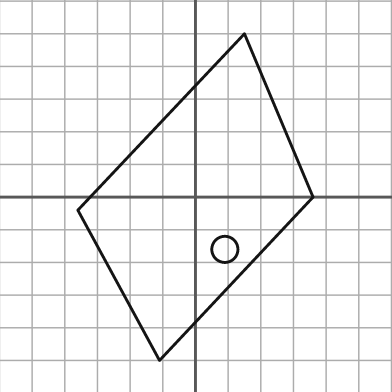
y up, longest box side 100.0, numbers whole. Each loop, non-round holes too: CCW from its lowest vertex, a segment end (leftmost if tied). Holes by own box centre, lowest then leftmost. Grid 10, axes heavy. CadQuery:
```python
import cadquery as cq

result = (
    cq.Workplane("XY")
    .moveTo(-11.0, -50.0)
    .lineTo(36.0, 0.0)
    .lineTo(15.0, 50.0)
    .lineTo(-36.0, -4.0)
    .close()
    .moveTo(9.0, -16.0)
    .circle(4.0)
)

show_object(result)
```